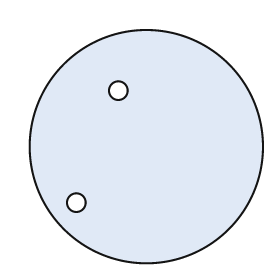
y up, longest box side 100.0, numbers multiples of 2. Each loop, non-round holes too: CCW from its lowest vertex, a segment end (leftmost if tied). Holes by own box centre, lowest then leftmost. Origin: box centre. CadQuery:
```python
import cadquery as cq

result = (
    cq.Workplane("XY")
    .moveTo(0.0, 0.0)
    .circle(50.0)
    .moveTo(-30.0, -24.0)
    .circle(4.0)
    .moveTo(-12.0, 24.0)
    .circle(4.0)
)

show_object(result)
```